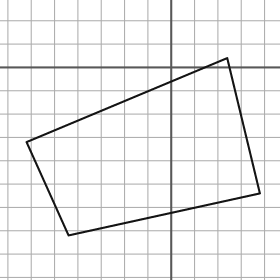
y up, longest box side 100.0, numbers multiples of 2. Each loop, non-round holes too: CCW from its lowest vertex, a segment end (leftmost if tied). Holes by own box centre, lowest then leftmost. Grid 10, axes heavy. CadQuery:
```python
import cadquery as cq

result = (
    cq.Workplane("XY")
    .moveTo(-44.0, -72.0)
    .lineTo(38.0, -54.0)
    .lineTo(24.0, 4.0)
    .lineTo(-62.0, -32.0)
    .close()
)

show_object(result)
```